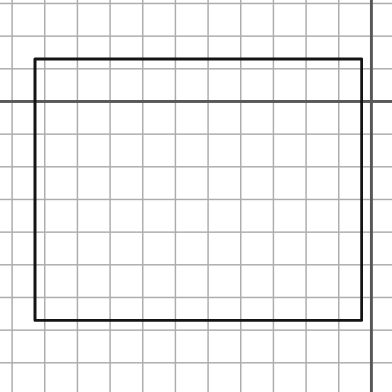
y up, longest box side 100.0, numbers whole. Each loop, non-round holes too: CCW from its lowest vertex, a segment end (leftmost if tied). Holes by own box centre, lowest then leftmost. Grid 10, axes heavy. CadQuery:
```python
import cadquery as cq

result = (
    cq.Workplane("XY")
    .moveTo(-103.0, -67.0)
    .lineTo(-3.0, -67.0)
    .lineTo(-3.0, 13.0)
    .lineTo(-103.0, 13.0)
    .close()
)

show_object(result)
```